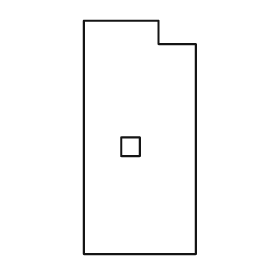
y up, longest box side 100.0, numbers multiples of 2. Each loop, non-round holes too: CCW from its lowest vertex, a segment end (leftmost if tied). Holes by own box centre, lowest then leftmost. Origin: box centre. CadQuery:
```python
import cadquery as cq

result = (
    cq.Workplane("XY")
    .moveTo(-24.0, -50.0)
    .lineTo(24.0, -50.0)
    .lineTo(24.0, 40.0)
    .lineTo(8.0, 40.0)
    .lineTo(8.0, 50.0)
    .lineTo(-24.0, 50.0)
    .close()
    .moveTo(-8.0, -8.0)
    .lineTo(0.0, -8.0)
    .lineTo(0.0, 0.0)
    .lineTo(-8.0, 0.0)
    .close()
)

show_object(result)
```